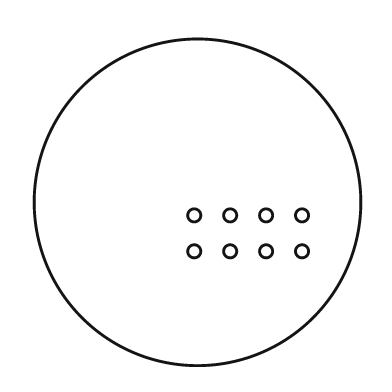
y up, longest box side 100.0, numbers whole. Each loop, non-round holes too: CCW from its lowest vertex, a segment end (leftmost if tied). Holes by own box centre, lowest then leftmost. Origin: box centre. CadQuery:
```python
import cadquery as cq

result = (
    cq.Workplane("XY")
    .moveTo(0.0, 0.0)
    .circle(50.0)
    .moveTo(-1.0, -15.0)
    .circle(2.0)
    .moveTo(10.0, -15.0)
    .circle(2.0)
    .moveTo(21.0, -15.0)
    .circle(2.0)
    .moveTo(32.0, -15.0)
    .circle(2.0)
    .moveTo(-1.0, -4.0)
    .circle(2.0)
    .moveTo(10.0, -4.0)
    .circle(2.0)
    .moveTo(21.0, -4.0)
    .circle(2.0)
    .moveTo(32.0, -4.0)
    .circle(2.0)
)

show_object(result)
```